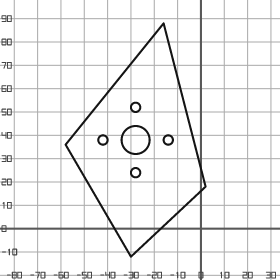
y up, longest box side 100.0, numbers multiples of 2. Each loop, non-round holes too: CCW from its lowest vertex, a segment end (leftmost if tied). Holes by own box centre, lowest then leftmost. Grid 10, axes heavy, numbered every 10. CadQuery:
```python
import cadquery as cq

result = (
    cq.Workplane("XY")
    .moveTo(-30.0, -12.0)
    .lineTo(2.0, 18.0)
    .lineTo(-16.0, 88.0)
    .lineTo(-58.0, 36.0)
    .close()
    .moveTo(-28.0, 24.0)
    .circle(2.0)
    .moveTo(-42.0, 38.0)
    .circle(2.0)
    .moveTo(-28.0, 38.0)
    .circle(6.0)
    .moveTo(-14.0, 38.0)
    .circle(2.0)
    .moveTo(-28.0, 52.0)
    .circle(2.0)
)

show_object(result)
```